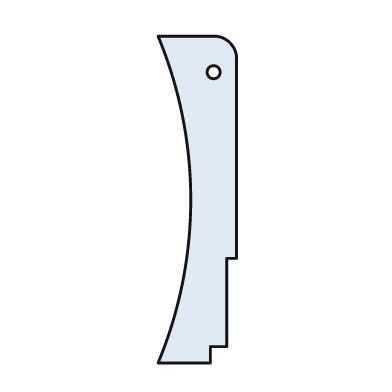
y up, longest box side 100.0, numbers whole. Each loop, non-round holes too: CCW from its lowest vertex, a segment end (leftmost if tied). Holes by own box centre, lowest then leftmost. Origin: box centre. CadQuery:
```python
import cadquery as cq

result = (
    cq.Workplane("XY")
    .moveTo(-12.0, -50.0)
    .lineTo(4.0, -50.0)
    .lineTo(4.0, -45.0)
    .lineTo(9.0, -45.0)
    .lineTo(9.0, -18.0)
    .lineTo(12.0, -18.0)
    .lineTo(12.0, 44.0)
    .threePointArc((10.0, 48.0), (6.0, 50.0))
    .lineTo(-12.0, 50.0)
    .threePointArc((-2.0, 0.0), (-12.0, -50.0))
    .close()
    .moveTo(5.0, 39.0)
    .circle(2.0)
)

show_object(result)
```